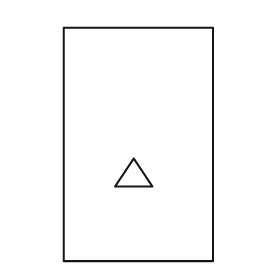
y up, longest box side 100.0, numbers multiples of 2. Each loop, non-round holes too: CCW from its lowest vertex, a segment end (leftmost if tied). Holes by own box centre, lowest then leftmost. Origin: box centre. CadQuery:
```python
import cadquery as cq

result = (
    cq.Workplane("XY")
    .moveTo(-32.0, -50.0)
    .lineTo(32.0, -50.0)
    .lineTo(32.0, 50.0)
    .lineTo(-32.0, 50.0)
    .close()
    .moveTo(-10.0, -18.0)
    .lineTo(6.0, -18.0)
    .lineTo(-2.0, -6.0)
    .close()
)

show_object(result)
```